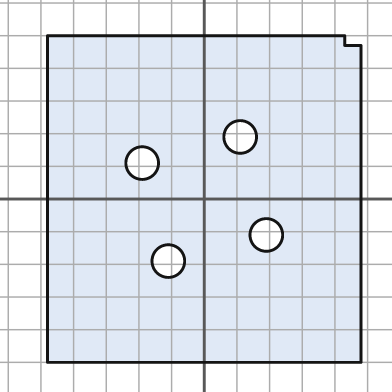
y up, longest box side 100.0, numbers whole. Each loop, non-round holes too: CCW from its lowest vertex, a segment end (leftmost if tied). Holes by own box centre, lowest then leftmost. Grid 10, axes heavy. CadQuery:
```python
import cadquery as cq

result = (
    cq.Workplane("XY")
    .moveTo(-48.0, -50.0)
    .lineTo(48.0, -50.0)
    .lineTo(48.0, 47.0)
    .lineTo(43.0, 47.0)
    .lineTo(43.0, 50.0)
    .lineTo(-48.0, 50.0)
    .close()
    .moveTo(-11.0, -19.0)
    .circle(5.0)
    .moveTo(19.0, -11.0)
    .circle(5.0)
    .moveTo(-19.0, 11.0)
    .circle(5.0)
    .moveTo(11.0, 19.0)
    .circle(5.0)
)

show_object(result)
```